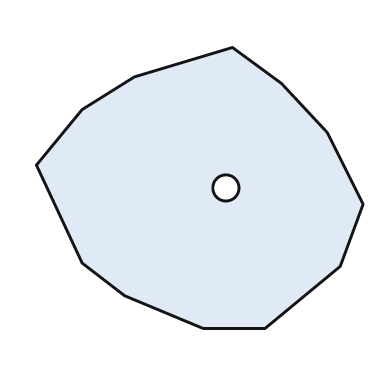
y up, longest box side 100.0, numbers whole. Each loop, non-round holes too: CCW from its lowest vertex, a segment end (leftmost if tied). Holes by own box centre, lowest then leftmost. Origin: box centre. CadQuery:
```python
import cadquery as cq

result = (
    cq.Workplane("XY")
    .moveTo(1.0, -43.0)
    .lineTo(20.0, -43.0)
    .lineTo(43.0, -24.0)
    .lineTo(50.0, -5.0)
    .lineTo(39.0, 17.0)
    .lineTo(25.0, 32.0)
    .lineTo(10.0, 43.0)
    .lineTo(-20.0, 34.0)
    .lineTo(-36.0, 24.0)
    .lineTo(-50.0, 7.0)
    .lineTo(-36.0, -23.0)
    .lineTo(-23.0, -33.0)
    .close()
    .moveTo(8.0, 0.0)
    .circle(4.0)
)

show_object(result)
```